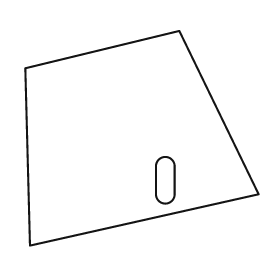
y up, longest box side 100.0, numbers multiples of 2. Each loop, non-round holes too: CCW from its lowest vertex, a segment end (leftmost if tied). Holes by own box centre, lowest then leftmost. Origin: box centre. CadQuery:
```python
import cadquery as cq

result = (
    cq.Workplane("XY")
    .moveTo(-48.0, -46.0)
    .lineTo(50.0, -24.0)
    .lineTo(16.0, 46.0)
    .lineTo(-50.0, 30.0)
    .close()
    .moveTo(6.0, -24.0)
    .threePointArc((10.0, -28.0), (14.0, -24.0))
    .lineTo(14.0, -12.0)
    .threePointArc((10.0, -8.0), (6.0, -12.0))
    .close()
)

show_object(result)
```